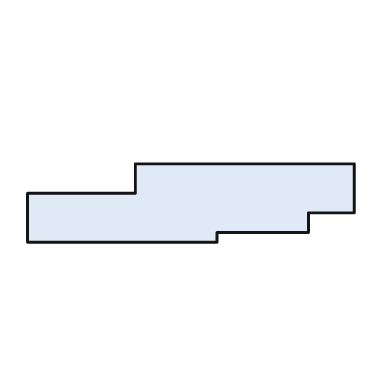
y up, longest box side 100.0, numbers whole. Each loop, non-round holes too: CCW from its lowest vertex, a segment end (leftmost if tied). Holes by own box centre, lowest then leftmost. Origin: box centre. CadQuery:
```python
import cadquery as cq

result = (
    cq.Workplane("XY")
    .moveTo(-50.0, -12.0)
    .lineTo(8.0, -12.0)
    .lineTo(8.0, -9.0)
    .lineTo(36.0, -9.0)
    .lineTo(36.0, -3.0)
    .lineTo(50.0, -3.0)
    .lineTo(50.0, 12.0)
    .lineTo(-17.0, 12.0)
    .lineTo(-17.0, 3.0)
    .lineTo(-50.0, 3.0)
    .close()
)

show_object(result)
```